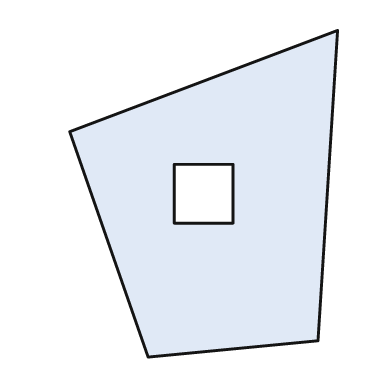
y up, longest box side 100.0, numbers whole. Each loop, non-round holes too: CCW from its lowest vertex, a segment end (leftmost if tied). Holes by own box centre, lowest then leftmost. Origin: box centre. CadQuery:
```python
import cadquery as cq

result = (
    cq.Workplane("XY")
    .moveTo(-17.0, -50.0)
    .lineTo(35.0, -45.0)
    .lineTo(41.0, 50.0)
    .lineTo(-41.0, 19.0)
    .close()
    .moveTo(-9.0, -9.0)
    .lineTo(9.0, -9.0)
    .lineTo(9.0, 9.0)
    .lineTo(-9.0, 9.0)
    .close()
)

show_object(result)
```